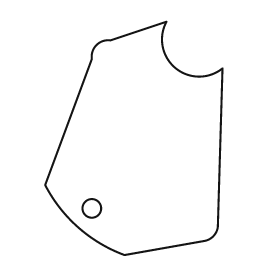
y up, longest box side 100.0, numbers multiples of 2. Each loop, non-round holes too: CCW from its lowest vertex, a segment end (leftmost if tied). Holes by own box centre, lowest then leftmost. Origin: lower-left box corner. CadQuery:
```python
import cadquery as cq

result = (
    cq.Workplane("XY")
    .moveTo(34.0, 0.0)
    .lineTo(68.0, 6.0)
    .threePointArc((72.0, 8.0), (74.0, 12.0))
    .lineTo(76.0, 80.0)
    .threePointArc((56.0, 80.0), (52.0, 100.0))
    .lineTo(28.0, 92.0)
    .threePointArc((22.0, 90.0), (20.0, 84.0))
    .lineTo(0.0, 30.0)
    .threePointArc((14.0, 12.0), (34.0, 0.0))
    .close()
    .moveTo(20.0, 20.0)
    .circle(4.0)
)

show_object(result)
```